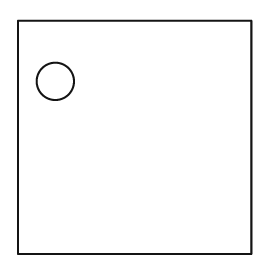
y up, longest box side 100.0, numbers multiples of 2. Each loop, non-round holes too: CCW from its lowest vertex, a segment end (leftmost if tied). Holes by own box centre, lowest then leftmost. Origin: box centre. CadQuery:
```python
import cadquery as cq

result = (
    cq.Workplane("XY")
    .moveTo(-50.0, -50.0)
    .lineTo(50.0, -50.0)
    .lineTo(50.0, 50.0)
    .lineTo(-50.0, 50.0)
    .close()
    .moveTo(-34.0, 24.0)
    .circle(8.0)
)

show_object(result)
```